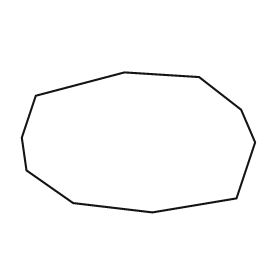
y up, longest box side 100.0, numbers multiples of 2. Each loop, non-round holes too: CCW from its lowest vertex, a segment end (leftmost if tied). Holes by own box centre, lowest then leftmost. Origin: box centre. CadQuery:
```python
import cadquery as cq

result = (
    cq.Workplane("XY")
    .moveTo(6.0, -30.0)
    .lineTo(42.0, -24.0)
    .lineTo(50.0, 0.0)
    .lineTo(44.0, 14.0)
    .lineTo(26.0, 28.0)
    .lineTo(-6.0, 30.0)
    .lineTo(-44.0, 20.0)
    .lineTo(-50.0, 2.0)
    .lineTo(-48.0, -12.0)
    .lineTo(-28.0, -26.0)
    .close()
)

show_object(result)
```